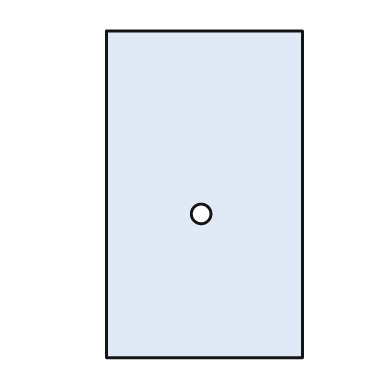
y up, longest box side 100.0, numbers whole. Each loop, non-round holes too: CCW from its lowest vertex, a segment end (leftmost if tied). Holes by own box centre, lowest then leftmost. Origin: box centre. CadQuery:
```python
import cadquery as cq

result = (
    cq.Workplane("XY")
    .moveTo(-30.0, -50.0)
    .lineTo(30.0, -50.0)
    .lineTo(30.0, 50.0)
    .lineTo(-30.0, 50.0)
    .close()
    .moveTo(-1.0, -6.0)
    .circle(3.0)
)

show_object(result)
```